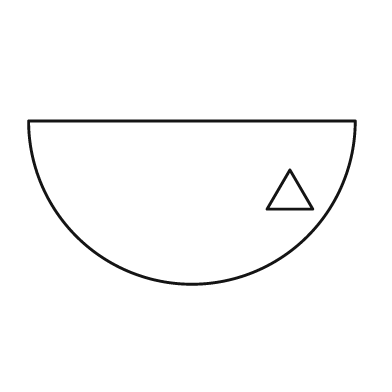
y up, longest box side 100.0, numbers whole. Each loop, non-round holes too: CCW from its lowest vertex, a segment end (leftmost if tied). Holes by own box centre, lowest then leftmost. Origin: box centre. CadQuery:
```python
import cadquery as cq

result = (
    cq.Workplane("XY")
    .moveTo(-50.0, 25.0)
    .threePointArc((0.0, -25.0), (50.0, 25.0))
    .close()
    .moveTo(23.0, -2.0)
    .lineTo(37.0, -2.0)
    .lineTo(30.0, 10.0)
    .close()
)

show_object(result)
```